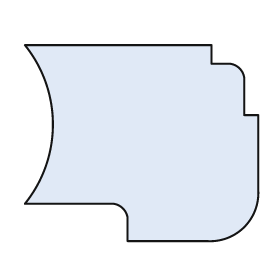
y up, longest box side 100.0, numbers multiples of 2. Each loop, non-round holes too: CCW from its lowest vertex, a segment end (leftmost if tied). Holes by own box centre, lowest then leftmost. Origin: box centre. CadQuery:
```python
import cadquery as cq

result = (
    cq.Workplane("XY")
    .moveTo(-6.0, -42.0)
    .lineTo(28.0, -42.0)
    .threePointArc((44.0, -36.0), (50.0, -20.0))
    .lineTo(50.0, 12.0)
    .lineTo(44.0, 12.0)
    .lineTo(44.0, 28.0)
    .threePointArc((42.0, 32.0), (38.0, 34.0))
    .lineTo(30.0, 34.0)
    .lineTo(30.0, 42.0)
    .lineTo(-50.0, 42.0)
    .threePointArc((-38.0, 8.0), (-50.0, -26.0))
    .lineTo(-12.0, -26.0)
    .threePointArc((-8.0, -28.0), (-6.0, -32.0))
    .close()
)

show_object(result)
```